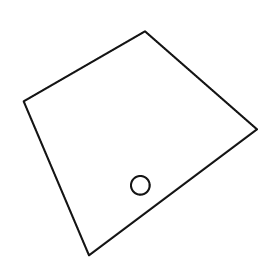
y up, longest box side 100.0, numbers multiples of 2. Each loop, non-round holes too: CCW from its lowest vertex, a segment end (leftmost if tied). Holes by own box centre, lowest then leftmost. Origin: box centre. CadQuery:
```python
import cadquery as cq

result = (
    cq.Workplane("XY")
    .moveTo(-22.0, -48.0)
    .lineTo(50.0, 6.0)
    .lineTo(2.0, 48.0)
    .lineTo(-50.0, 18.0)
    .close()
    .moveTo(0.0, -18.0)
    .circle(4.0)
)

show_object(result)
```